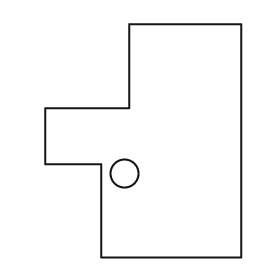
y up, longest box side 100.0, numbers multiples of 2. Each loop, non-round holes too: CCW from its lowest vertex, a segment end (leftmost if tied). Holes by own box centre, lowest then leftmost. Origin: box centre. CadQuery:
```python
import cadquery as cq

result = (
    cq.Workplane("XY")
    .moveTo(-18.0, -50.0)
    .lineTo(42.0, -50.0)
    .lineTo(42.0, 50.0)
    .lineTo(-6.0, 50.0)
    .lineTo(-6.0, 14.0)
    .lineTo(-42.0, 14.0)
    .lineTo(-42.0, -10.0)
    .lineTo(-18.0, -10.0)
    .close()
    .moveTo(-8.0, -14.0)
    .circle(6.0)
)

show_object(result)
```